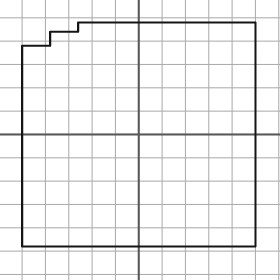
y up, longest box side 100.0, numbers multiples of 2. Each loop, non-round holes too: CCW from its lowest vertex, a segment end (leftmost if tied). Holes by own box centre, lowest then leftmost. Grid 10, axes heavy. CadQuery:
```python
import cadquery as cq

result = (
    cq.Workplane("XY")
    .moveTo(-50.0, -48.0)
    .lineTo(50.0, -48.0)
    .lineTo(50.0, 48.0)
    .lineTo(-26.0, 48.0)
    .lineTo(-26.0, 44.0)
    .lineTo(-38.0, 44.0)
    .lineTo(-38.0, 38.0)
    .lineTo(-50.0, 38.0)
    .close()
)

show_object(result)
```